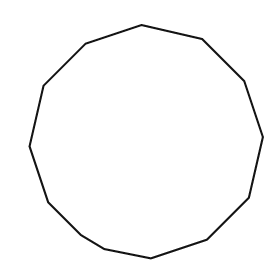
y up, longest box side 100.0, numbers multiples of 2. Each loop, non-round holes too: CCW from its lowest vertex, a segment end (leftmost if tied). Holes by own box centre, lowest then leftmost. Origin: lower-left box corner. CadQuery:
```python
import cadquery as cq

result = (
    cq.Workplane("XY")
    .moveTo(52.0, 0.0)
    .lineTo(76.0, 8.0)
    .lineTo(94.0, 26.0)
    .lineTo(100.0, 52.0)
    .lineTo(92.0, 76.0)
    .lineTo(74.0, 94.0)
    .lineTo(48.0, 100.0)
    .lineTo(24.0, 92.0)
    .lineTo(6.0, 74.0)
    .lineTo(0.0, 48.0)
    .lineTo(8.0, 24.0)
    .lineTo(22.0, 10.0)
    .lineTo(32.0, 4.0)
    .close()
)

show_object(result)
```